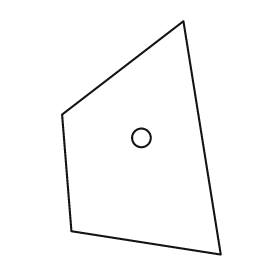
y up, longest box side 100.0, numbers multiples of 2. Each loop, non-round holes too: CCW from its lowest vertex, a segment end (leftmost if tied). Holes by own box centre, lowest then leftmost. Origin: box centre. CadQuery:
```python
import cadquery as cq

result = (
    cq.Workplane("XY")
    .moveTo(34.0, -50.0)
    .lineTo(18.0, 50.0)
    .lineTo(-34.0, 10.0)
    .lineTo(-30.0, -40.0)
    .close()
    .moveTo(0.0, 0.0)
    .circle(4.0)
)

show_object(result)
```